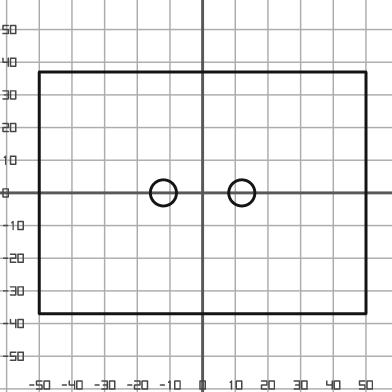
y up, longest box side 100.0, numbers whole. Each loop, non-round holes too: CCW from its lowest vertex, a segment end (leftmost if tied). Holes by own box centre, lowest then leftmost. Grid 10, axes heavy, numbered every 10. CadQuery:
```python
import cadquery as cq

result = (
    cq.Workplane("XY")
    .moveTo(-50.0, -37.0)
    .lineTo(50.0, -37.0)
    .lineTo(50.0, 37.0)
    .lineTo(-50.0, 37.0)
    .close()
    .moveTo(-12.0, 0.0)
    .circle(4.0)
    .moveTo(12.0, 0.0)
    .circle(4.0)
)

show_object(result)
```